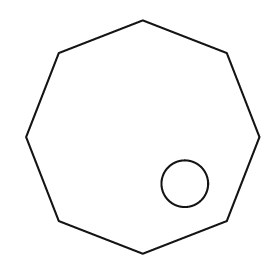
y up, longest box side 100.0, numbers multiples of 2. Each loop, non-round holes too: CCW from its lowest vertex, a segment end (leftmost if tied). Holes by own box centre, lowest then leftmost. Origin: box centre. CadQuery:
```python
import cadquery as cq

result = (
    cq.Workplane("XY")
    .moveTo(0.0, -50.0)
    .lineTo(36.0, -36.0)
    .lineTo(50.0, 0.0)
    .lineTo(36.0, 36.0)
    .lineTo(0.0, 50.0)
    .lineTo(-36.0, 36.0)
    .lineTo(-50.0, 0.0)
    .lineTo(-36.0, -36.0)
    .close()
    .moveTo(18.0, -20.0)
    .circle(10.0)
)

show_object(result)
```